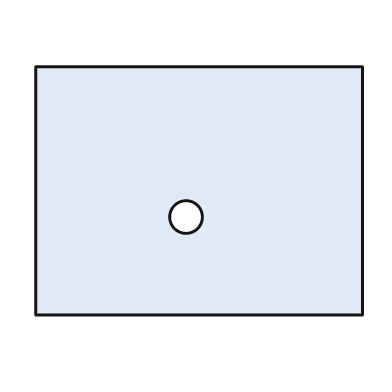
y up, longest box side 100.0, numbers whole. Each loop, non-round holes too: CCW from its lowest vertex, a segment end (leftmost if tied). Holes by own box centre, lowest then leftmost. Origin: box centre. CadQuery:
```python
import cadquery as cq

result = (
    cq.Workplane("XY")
    .moveTo(-50.0, -38.0)
    .lineTo(50.0, -38.0)
    .lineTo(50.0, 38.0)
    .lineTo(-50.0, 38.0)
    .close()
    .moveTo(-4.0, -8.0)
    .circle(5.0)
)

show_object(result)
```